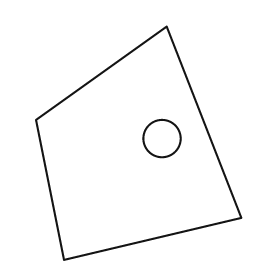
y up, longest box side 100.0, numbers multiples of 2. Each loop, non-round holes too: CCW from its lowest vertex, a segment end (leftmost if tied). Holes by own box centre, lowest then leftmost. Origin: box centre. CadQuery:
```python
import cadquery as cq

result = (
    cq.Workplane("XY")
    .moveTo(-32.0, -50.0)
    .lineTo(44.0, -32.0)
    .lineTo(12.0, 50.0)
    .lineTo(-44.0, 10.0)
    .close()
    .moveTo(10.0, 2.0)
    .circle(8.0)
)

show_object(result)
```